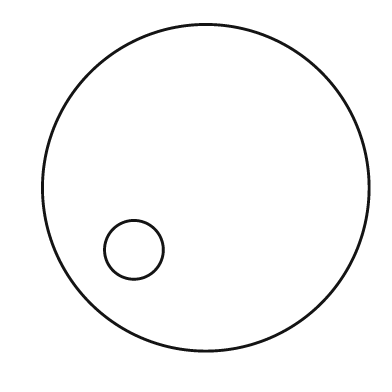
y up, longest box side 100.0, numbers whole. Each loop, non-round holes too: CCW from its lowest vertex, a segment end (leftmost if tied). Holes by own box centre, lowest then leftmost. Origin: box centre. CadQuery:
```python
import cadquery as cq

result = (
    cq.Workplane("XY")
    .moveTo(0.0, 0.0)
    .circle(50.0)
    .moveTo(-22.0, -19.0)
    .circle(9.0)
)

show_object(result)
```